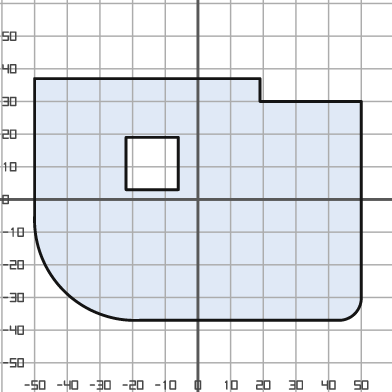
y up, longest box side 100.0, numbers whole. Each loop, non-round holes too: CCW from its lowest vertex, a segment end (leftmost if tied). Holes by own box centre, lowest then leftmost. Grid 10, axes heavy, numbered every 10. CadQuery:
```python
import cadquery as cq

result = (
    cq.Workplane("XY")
    .moveTo(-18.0, -37.0)
    .lineTo(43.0, -37.0)
    .threePointArc((48.0, -35.0), (50.0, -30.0))
    .lineTo(50.0, 30.0)
    .lineTo(19.0, 30.0)
    .lineTo(19.0, 37.0)
    .lineTo(-50.0, 37.0)
    .lineTo(-50.0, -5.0)
    .threePointArc((-41.0, -28.0), (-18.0, -37.0))
    .close()
    .moveTo(-22.0, 3.0)
    .lineTo(-6.0, 3.0)
    .lineTo(-6.0, 19.0)
    .lineTo(-22.0, 19.0)
    .close()
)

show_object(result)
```